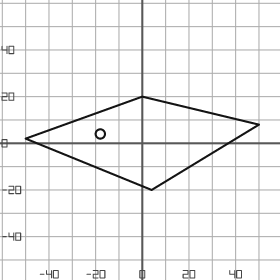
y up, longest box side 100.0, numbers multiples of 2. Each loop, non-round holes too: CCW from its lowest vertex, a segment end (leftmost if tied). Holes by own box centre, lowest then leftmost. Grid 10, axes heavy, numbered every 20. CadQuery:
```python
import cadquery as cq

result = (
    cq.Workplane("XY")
    .moveTo(4.0, -20.0)
    .lineTo(50.0, 8.0)
    .lineTo(0.0, 20.0)
    .lineTo(-50.0, 2.0)
    .close()
    .moveTo(-18.0, 4.0)
    .circle(2.0)
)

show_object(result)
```